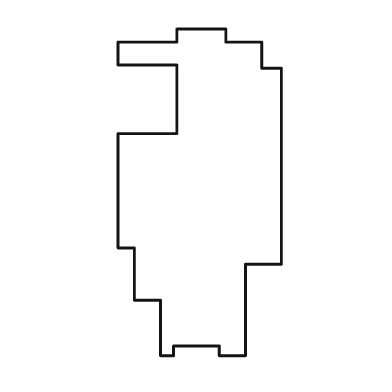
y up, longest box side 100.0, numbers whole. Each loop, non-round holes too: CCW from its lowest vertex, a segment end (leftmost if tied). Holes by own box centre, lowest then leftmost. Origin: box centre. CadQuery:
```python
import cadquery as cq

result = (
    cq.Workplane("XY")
    .moveTo(-12.0, -50.0)
    .lineTo(-8.0, -50.0)
    .lineTo(-8.0, -47.0)
    .lineTo(6.0, -47.0)
    .lineTo(6.0, -50.0)
    .lineTo(14.0, -50.0)
    .lineTo(14.0, -22.0)
    .lineTo(25.0, -22.0)
    .lineTo(25.0, 38.0)
    .lineTo(19.0, 38.0)
    .lineTo(19.0, 46.0)
    .lineTo(8.0, 46.0)
    .lineTo(8.0, 50.0)
    .lineTo(-7.0, 50.0)
    .lineTo(-7.0, 46.0)
    .lineTo(-25.0, 46.0)
    .lineTo(-25.0, 39.0)
    .lineTo(-7.0, 39.0)
    .lineTo(-7.0, 18.0)
    .lineTo(-25.0, 18.0)
    .lineTo(-25.0, -17.0)
    .lineTo(-20.0, -17.0)
    .lineTo(-20.0, -33.0)
    .lineTo(-12.0, -33.0)
    .close()
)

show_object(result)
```